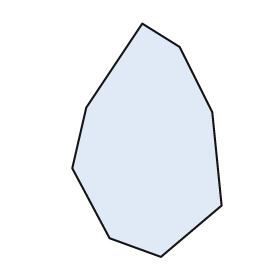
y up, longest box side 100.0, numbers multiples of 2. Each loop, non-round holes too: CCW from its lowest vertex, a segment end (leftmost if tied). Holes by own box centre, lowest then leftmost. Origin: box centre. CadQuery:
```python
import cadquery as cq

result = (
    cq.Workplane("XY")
    .moveTo(6.0, -50.0)
    .lineTo(32.0, -28.0)
    .lineTo(28.0, 12.0)
    .lineTo(14.0, 40.0)
    .lineTo(-2.0, 50.0)
    .lineTo(-26.0, 14.0)
    .lineTo(-32.0, -12.0)
    .lineTo(-16.0, -42.0)
    .close()
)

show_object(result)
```